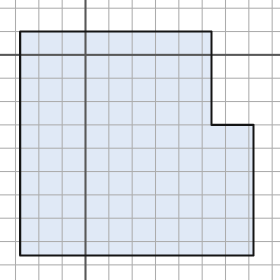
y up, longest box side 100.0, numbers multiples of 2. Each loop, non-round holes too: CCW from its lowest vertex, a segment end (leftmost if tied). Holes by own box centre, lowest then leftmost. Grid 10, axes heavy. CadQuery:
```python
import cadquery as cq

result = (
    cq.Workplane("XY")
    .moveTo(-28.0, -86.0)
    .lineTo(72.0, -86.0)
    .lineTo(72.0, -30.0)
    .lineTo(54.0, -30.0)
    .lineTo(54.0, 10.0)
    .lineTo(-28.0, 10.0)
    .close()
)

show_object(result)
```